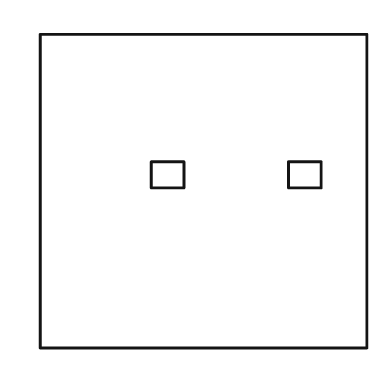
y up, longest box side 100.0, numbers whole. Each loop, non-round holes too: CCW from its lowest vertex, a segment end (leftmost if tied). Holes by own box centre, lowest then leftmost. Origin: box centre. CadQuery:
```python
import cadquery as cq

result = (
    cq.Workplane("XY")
    .moveTo(-50.0, -48.0)
    .lineTo(50.0, -48.0)
    .lineTo(50.0, 48.0)
    .lineTo(-50.0, 48.0)
    .close()
    .moveTo(-16.0, 1.0)
    .lineTo(-6.0, 1.0)
    .lineTo(-6.0, 9.0)
    .lineTo(-16.0, 9.0)
    .close()
    .moveTo(26.0, 1.0)
    .lineTo(36.0, 1.0)
    .lineTo(36.0, 9.0)
    .lineTo(26.0, 9.0)
    .close()
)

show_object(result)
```